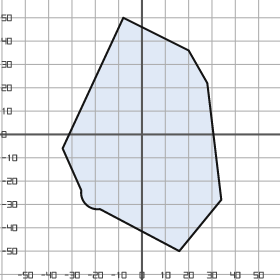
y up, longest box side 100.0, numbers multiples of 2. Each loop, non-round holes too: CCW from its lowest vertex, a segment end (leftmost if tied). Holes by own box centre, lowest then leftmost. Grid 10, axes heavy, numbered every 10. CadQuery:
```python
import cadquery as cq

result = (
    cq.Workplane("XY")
    .moveTo(16.0, -50.0)
    .lineTo(34.0, -28.0)
    .lineTo(28.0, 22.0)
    .lineTo(20.0, 36.0)
    .lineTo(-8.0, 50.0)
    .lineTo(-34.0, -6.0)
    .lineTo(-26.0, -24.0)
    .threePointArc((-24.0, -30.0), (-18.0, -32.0))
    .close()
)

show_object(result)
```